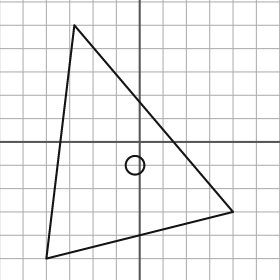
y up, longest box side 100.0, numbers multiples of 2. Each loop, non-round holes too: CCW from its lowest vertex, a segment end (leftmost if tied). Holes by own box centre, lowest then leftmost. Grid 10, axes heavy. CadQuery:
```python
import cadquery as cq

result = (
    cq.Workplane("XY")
    .moveTo(-40.0, -50.0)
    .lineTo(40.0, -30.0)
    .lineTo(-28.0, 50.0)
    .close()
    .moveTo(-2.0, -10.0)
    .circle(4.0)
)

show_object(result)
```